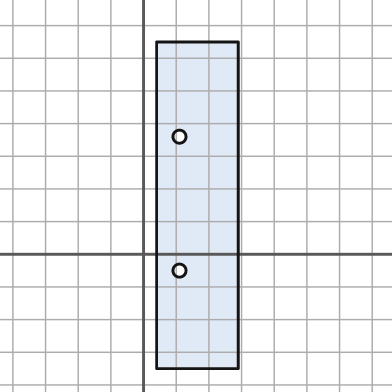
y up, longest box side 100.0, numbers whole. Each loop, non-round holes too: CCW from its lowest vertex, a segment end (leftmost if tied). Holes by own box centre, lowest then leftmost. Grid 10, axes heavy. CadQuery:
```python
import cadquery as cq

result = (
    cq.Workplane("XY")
    .moveTo(4.0, -35.0)
    .lineTo(29.0, -35.0)
    .lineTo(29.0, 65.0)
    .lineTo(4.0, 65.0)
    .close()
    .moveTo(11.0, -5.0)
    .circle(2.0)
    .moveTo(11.0, 36.0)
    .circle(2.0)
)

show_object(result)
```